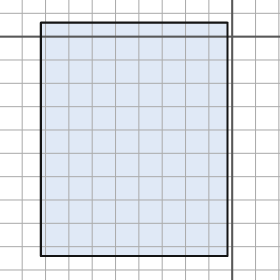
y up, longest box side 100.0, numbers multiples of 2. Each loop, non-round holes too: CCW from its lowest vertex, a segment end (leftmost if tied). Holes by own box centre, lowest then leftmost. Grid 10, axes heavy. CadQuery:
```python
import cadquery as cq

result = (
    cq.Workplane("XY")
    .moveTo(-82.0, -94.0)
    .lineTo(-2.0, -94.0)
    .lineTo(-2.0, 6.0)
    .lineTo(-82.0, 6.0)
    .close()
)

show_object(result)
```